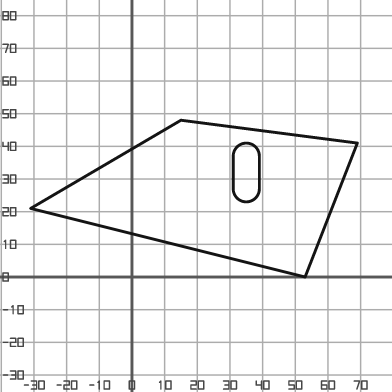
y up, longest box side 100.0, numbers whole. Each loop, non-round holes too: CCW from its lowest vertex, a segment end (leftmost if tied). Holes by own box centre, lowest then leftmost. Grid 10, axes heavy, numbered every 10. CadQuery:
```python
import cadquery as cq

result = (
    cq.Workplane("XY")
    .moveTo(53.0, 0.0)
    .lineTo(69.0, 41.0)
    .lineTo(15.0, 48.0)
    .lineTo(-31.0, 21.0)
    .close()
    .moveTo(31.0, 27.0)
    .threePointArc((35.0, 23.0), (39.0, 27.0))
    .lineTo(39.0, 37.0)
    .threePointArc((35.0, 41.0), (31.0, 37.0))
    .close()
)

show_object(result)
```